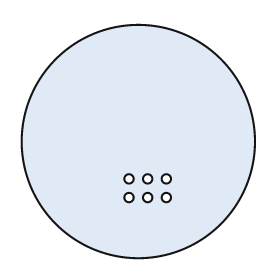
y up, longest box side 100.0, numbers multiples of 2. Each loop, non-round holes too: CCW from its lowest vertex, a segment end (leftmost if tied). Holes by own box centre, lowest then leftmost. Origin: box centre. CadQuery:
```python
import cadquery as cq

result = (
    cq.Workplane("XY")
    .moveTo(0.0, 0.0)
    .circle(50.0)
    .moveTo(-4.0, -24.0)
    .circle(2.0)
    .moveTo(4.0, -24.0)
    .circle(2.0)
    .moveTo(12.0, -24.0)
    .circle(2.0)
    .moveTo(-4.0, -16.0)
    .circle(2.0)
    .moveTo(4.0, -16.0)
    .circle(2.0)
    .moveTo(12.0, -16.0)
    .circle(2.0)
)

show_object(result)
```